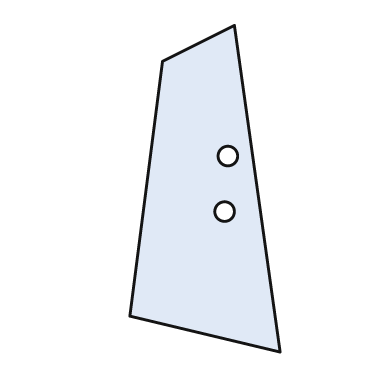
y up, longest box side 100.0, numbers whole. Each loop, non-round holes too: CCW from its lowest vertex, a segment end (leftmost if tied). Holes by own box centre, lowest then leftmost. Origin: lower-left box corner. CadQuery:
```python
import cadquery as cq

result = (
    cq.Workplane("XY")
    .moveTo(46.0, 0.0)
    .lineTo(32.0, 100.0)
    .lineTo(10.0, 89.0)
    .lineTo(0.0, 11.0)
    .close()
    .moveTo(29.0, 43.0)
    .circle(3.0)
    .moveTo(30.0, 60.0)
    .circle(3.0)
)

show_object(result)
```